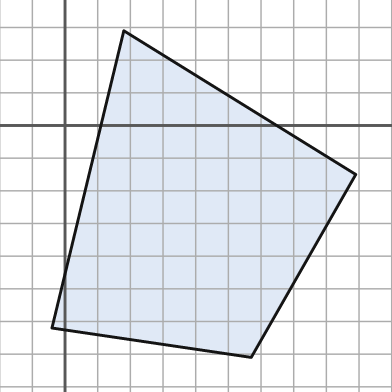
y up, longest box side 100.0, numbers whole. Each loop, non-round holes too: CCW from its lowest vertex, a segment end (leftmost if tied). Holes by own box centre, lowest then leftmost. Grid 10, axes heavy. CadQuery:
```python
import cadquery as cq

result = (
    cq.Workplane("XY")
    .moveTo(57.0, -71.0)
    .lineTo(89.0, -15.0)
    .lineTo(18.0, 29.0)
    .lineTo(-4.0, -62.0)
    .close()
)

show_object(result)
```